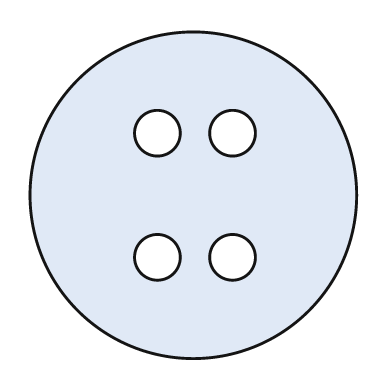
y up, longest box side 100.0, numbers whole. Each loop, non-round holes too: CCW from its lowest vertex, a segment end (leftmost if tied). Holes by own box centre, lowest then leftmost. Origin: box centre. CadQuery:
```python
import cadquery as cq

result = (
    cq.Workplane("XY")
    .moveTo(0.0, 0.0)
    .circle(50.0)
    .moveTo(-11.0, -19.0)
    .circle(7.0)
    .moveTo(12.0, -19.0)
    .circle(7.0)
    .moveTo(-11.0, 19.0)
    .circle(7.0)
    .moveTo(12.0, 19.0)
    .circle(7.0)
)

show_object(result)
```